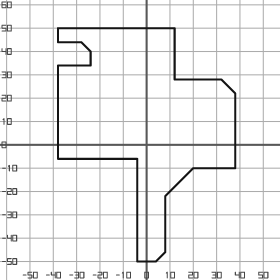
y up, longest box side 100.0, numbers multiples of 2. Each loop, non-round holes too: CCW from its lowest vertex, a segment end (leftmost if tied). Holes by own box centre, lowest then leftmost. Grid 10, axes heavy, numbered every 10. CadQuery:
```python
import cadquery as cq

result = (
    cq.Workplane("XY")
    .moveTo(-4.0, -50.0)
    .lineTo(4.0, -50.0)
    .lineTo(8.0, -46.0)
    .lineTo(8.0, -22.0)
    .lineTo(20.0, -10.0)
    .lineTo(38.0, -10.0)
    .lineTo(38.0, 22.0)
    .lineTo(32.0, 28.0)
    .lineTo(12.0, 28.0)
    .lineTo(12.0, 50.0)
    .lineTo(-38.0, 50.0)
    .lineTo(-38.0, 44.0)
    .lineTo(-28.0, 44.0)
    .lineTo(-24.0, 40.0)
    .lineTo(-24.0, 34.0)
    .lineTo(-38.0, 34.0)
    .lineTo(-38.0, -6.0)
    .lineTo(-4.0, -6.0)
    .close()
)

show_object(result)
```